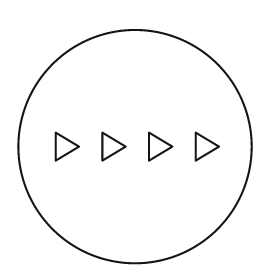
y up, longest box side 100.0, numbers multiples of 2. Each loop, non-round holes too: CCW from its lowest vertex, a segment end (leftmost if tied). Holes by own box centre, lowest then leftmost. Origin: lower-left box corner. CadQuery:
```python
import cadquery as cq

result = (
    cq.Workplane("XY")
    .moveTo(50.0, 50.0)
    .circle(50.0)
    .moveTo(16.0, 44.0)
    .lineTo(26.0, 50.0)
    .lineTo(16.0, 56.0)
    .close()
    .moveTo(36.0, 44.0)
    .lineTo(46.0, 50.0)
    .lineTo(36.0, 56.0)
    .close()
    .moveTo(56.0, 44.0)
    .lineTo(66.0, 50.0)
    .lineTo(56.0, 56.0)
    .close()
    .moveTo(76.0, 44.0)
    .lineTo(86.0, 50.0)
    .lineTo(76.0, 56.0)
    .close()
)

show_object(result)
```